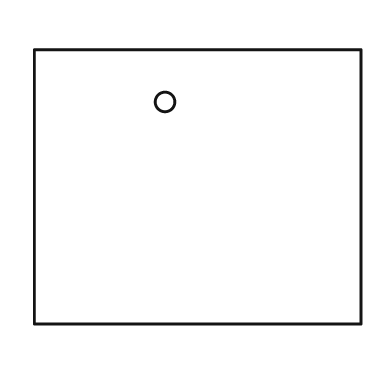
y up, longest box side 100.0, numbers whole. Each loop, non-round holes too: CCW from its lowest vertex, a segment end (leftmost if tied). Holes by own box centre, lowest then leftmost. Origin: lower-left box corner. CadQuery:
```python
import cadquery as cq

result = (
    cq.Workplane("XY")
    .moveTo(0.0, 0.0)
    .lineTo(100.0, 0.0)
    .lineTo(100.0, 84.0)
    .lineTo(0.0, 84.0)
    .close()
    .moveTo(40.0, 68.0)
    .circle(3.0)
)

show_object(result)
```